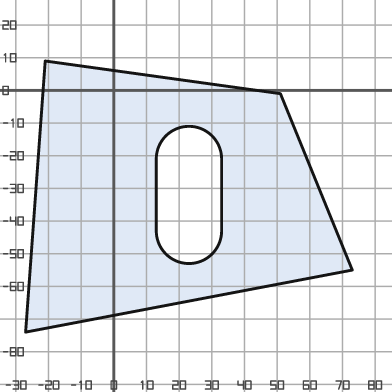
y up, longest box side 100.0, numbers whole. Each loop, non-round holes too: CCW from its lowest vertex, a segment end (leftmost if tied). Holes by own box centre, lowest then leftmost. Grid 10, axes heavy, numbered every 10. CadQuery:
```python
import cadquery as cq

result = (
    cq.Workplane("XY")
    .moveTo(-27.0, -74.0)
    .lineTo(73.0, -55.0)
    .lineTo(51.0, -1.0)
    .lineTo(-21.0, 9.0)
    .close()
    .moveTo(13.0, -43.0)
    .threePointArc((23.0, -53.0), (33.0, -43.0))
    .lineTo(33.0, -21.0)
    .threePointArc((23.0, -11.0), (13.0, -21.0))
    .close()
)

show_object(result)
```